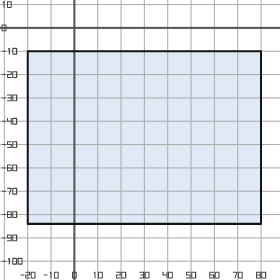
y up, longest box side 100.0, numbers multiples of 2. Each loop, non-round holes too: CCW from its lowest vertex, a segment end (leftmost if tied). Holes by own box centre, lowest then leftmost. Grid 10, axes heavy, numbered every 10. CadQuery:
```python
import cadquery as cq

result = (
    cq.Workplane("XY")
    .moveTo(-20.0, -84.0)
    .lineTo(80.0, -84.0)
    .lineTo(80.0, -10.0)
    .lineTo(-20.0, -10.0)
    .close()
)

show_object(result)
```